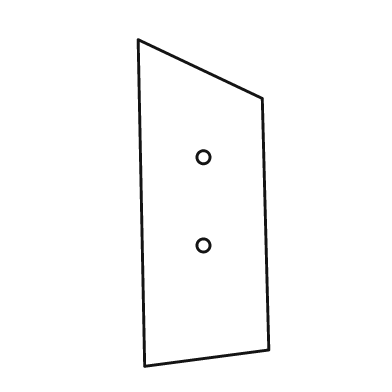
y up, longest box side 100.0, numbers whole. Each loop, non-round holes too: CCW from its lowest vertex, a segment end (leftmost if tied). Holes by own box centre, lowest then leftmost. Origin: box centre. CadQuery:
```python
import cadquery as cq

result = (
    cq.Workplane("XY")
    .moveTo(-18.0, -50.0)
    .lineTo(20.0, -45.0)
    .lineTo(18.0, 32.0)
    .lineTo(-20.0, 50.0)
    .close()
    .moveTo(0.0, -13.0)
    .circle(2.0)
    .moveTo(0.0, 14.0)
    .circle(2.0)
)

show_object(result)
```